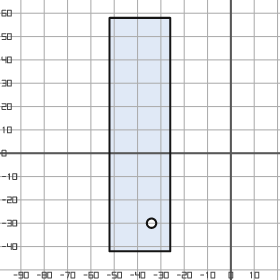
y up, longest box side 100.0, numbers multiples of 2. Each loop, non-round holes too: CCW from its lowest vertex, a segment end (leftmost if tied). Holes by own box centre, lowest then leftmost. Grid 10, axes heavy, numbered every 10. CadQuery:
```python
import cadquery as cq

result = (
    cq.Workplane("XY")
    .moveTo(-52.0, -42.0)
    .lineTo(-26.0, -42.0)
    .lineTo(-26.0, 58.0)
    .lineTo(-52.0, 58.0)
    .close()
    .moveTo(-34.0, -30.0)
    .circle(2.0)
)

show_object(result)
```